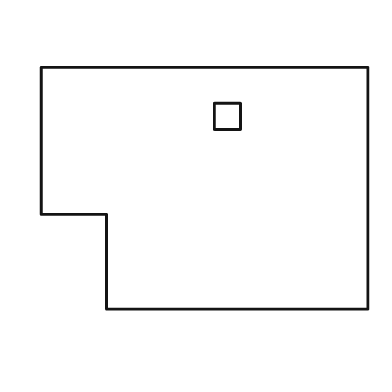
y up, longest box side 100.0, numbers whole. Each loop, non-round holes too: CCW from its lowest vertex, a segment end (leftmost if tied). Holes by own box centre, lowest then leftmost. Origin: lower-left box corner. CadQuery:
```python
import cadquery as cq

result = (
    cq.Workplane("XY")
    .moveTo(20.0, 0.0)
    .lineTo(100.0, 0.0)
    .lineTo(100.0, 74.0)
    .lineTo(0.0, 74.0)
    .lineTo(0.0, 29.0)
    .lineTo(20.0, 29.0)
    .close()
    .moveTo(53.0, 55.0)
    .lineTo(61.0, 55.0)
    .lineTo(61.0, 63.0)
    .lineTo(53.0, 63.0)
    .close()
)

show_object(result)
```